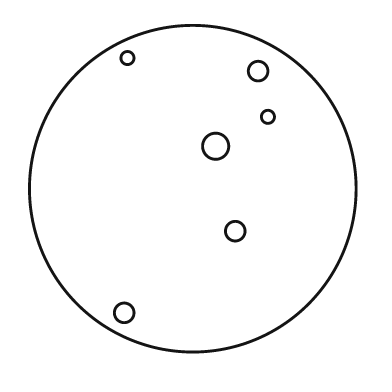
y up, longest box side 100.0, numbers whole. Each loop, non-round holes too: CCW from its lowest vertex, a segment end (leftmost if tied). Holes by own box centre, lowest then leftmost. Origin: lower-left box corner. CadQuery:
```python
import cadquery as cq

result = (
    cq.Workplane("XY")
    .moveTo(50.0, 50.0)
    .circle(50.0)
    .moveTo(29.0, 12.0)
    .circle(3.0)
    .moveTo(63.0, 37.0)
    .circle(3.0)
    .moveTo(57.0, 63.0)
    .circle(4.0)
    .moveTo(73.0, 72.0)
    .circle(2.0)
    .moveTo(70.0, 86.0)
    .circle(3.0)
    .moveTo(30.0, 90.0)
    .circle(2.0)
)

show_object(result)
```